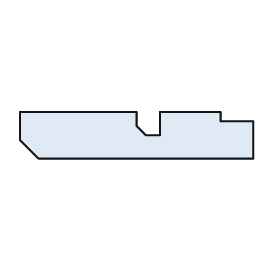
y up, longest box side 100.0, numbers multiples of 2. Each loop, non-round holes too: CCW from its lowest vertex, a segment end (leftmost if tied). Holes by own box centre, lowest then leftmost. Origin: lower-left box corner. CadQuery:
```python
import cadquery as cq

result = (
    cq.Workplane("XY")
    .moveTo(8.0, 0.0)
    .lineTo(100.0, 0.0)
    .lineTo(100.0, 16.0)
    .lineTo(86.0, 16.0)
    .lineTo(86.0, 20.0)
    .lineTo(60.0, 20.0)
    .lineTo(60.0, 10.0)
    .lineTo(54.0, 10.0)
    .lineTo(50.0, 14.0)
    .lineTo(50.0, 20.0)
    .lineTo(0.0, 20.0)
    .lineTo(0.0, 8.0)
    .close()
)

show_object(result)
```